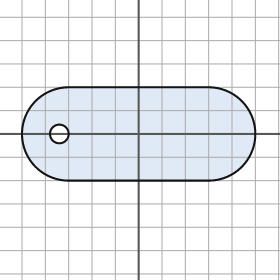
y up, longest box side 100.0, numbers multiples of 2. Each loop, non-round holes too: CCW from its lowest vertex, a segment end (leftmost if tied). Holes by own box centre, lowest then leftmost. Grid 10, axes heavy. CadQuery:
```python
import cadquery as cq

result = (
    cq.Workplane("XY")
    .moveTo(-30.0, -20.0)
    .lineTo(30.0, -20.0)
    .threePointArc((50.0, 0.0), (30.0, 20.0))
    .lineTo(-30.0, 20.0)
    .threePointArc((-50.0, 0.0), (-30.0, -20.0))
    .close()
    .moveTo(-34.0, 0.0)
    .circle(4.0)
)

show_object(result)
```